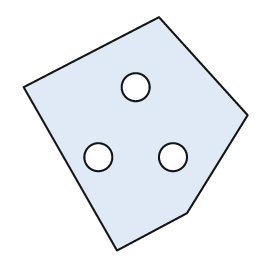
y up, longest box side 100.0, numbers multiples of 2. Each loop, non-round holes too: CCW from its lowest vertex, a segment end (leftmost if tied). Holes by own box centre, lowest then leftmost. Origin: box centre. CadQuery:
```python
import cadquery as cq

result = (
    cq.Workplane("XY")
    .moveTo(-8.0, -50.0)
    .lineTo(22.0, -34.0)
    .lineTo(48.0, 8.0)
    .lineTo(10.0, 50.0)
    .lineTo(-48.0, 20.0)
    .close()
    .moveTo(-16.0, -10.0)
    .circle(6.0)
    .moveTo(16.0, -10.0)
    .circle(6.0)
    .moveTo(0.0, 20.0)
    .circle(6.0)
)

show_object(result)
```